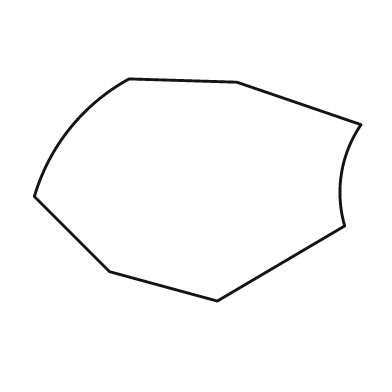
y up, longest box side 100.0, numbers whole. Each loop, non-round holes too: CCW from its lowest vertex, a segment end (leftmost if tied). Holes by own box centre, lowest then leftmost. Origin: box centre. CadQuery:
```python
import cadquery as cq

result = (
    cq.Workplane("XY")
    .moveTo(6.0, -34.0)
    .lineTo(45.0, -11.0)
    .threePointArc((44.0, 5.0), (50.0, 20.0))
    .lineTo(12.0, 33.0)
    .lineTo(-21.0, 34.0)
    .threePointArc((-39.0, 19.0), (-50.0, -2.0))
    .lineTo(-27.0, -25.0)
    .close()
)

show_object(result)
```